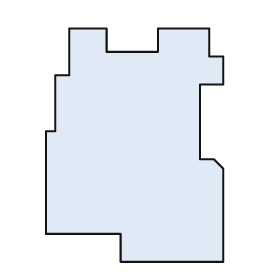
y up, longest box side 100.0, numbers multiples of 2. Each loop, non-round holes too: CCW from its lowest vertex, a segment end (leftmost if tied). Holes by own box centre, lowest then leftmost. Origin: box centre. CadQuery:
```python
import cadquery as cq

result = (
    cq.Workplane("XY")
    .moveTo(-6.0, -50.0)
    .lineTo(38.0, -50.0)
    .lineTo(38.0, -10.0)
    .lineTo(34.0, -6.0)
    .lineTo(28.0, -6.0)
    .lineTo(28.0, 26.0)
    .lineTo(38.0, 26.0)
    .lineTo(38.0, 38.0)
    .lineTo(32.0, 38.0)
    .lineTo(32.0, 50.0)
    .lineTo(10.0, 50.0)
    .lineTo(10.0, 40.0)
    .lineTo(-12.0, 40.0)
    .lineTo(-12.0, 50.0)
    .lineTo(-28.0, 50.0)
    .lineTo(-28.0, 30.0)
    .lineTo(-34.0, 30.0)
    .lineTo(-34.0, 6.0)
    .lineTo(-38.0, 6.0)
    .lineTo(-38.0, -38.0)
    .lineTo(-6.0, -38.0)
    .close()
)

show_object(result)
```